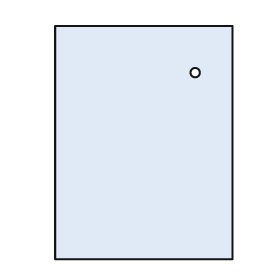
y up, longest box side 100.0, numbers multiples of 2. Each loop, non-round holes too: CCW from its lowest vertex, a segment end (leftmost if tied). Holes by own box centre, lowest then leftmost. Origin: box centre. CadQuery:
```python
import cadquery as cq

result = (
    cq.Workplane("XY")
    .moveTo(-38.0, -50.0)
    .lineTo(38.0, -50.0)
    .lineTo(38.0, 50.0)
    .lineTo(-38.0, 50.0)
    .close()
    .moveTo(22.0, 30.0)
    .circle(2.0)
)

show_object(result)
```